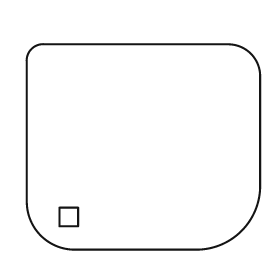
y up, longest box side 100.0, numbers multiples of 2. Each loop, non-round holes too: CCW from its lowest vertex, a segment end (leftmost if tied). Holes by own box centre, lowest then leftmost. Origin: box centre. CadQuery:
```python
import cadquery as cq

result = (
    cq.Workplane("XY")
    .moveTo(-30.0, -44.0)
    .lineTo(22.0, -44.0)
    .threePointArc((42.0, -36.0), (50.0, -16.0))
    .lineTo(50.0, 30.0)
    .threePointArc((46.0, 40.0), (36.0, 44.0))
    .lineTo(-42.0, 44.0)
    .threePointArc((-48.0, 42.0), (-50.0, 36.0))
    .lineTo(-50.0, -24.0)
    .threePointArc((-44.0, -38.0), (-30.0, -44.0))
    .close()
    .moveTo(-36.0, -34.0)
    .lineTo(-28.0, -34.0)
    .lineTo(-28.0, -26.0)
    .lineTo(-36.0, -26.0)
    .close()
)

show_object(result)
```